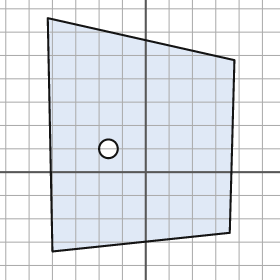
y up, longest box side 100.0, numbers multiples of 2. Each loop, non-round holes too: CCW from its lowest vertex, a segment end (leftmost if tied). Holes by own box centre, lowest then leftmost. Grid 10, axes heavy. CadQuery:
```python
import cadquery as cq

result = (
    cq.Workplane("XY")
    .moveTo(-40.0, -34.0)
    .lineTo(36.0, -26.0)
    .lineTo(38.0, 48.0)
    .lineTo(-42.0, 66.0)
    .close()
    .moveTo(-16.0, 10.0)
    .circle(4.0)
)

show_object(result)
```